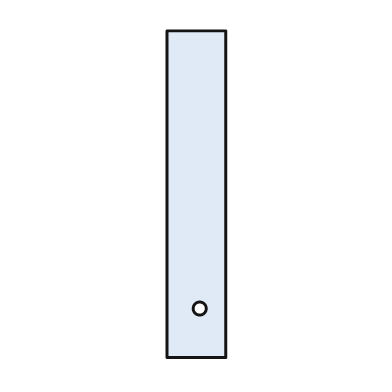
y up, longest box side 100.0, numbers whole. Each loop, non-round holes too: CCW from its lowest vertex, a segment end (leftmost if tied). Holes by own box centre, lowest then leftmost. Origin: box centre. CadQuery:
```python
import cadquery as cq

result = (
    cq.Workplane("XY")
    .moveTo(-9.0, -50.0)
    .lineTo(9.0, -50.0)
    .lineTo(9.0, 50.0)
    .lineTo(-9.0, 50.0)
    .close()
    .moveTo(1.0, -35.0)
    .circle(2.0)
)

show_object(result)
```